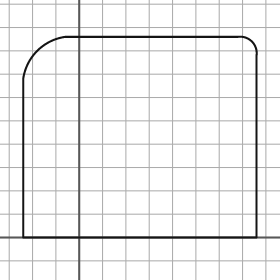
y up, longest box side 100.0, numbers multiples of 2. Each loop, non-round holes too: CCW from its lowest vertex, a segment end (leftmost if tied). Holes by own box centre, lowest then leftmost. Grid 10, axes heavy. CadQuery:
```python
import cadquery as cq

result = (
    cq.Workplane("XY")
    .moveTo(-24.0, 0.0)
    .lineTo(76.0, 0.0)
    .lineTo(76.0, 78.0)
    .threePointArc((74.0, 84.0), (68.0, 86.0))
    .lineTo(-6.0, 86.0)
    .threePointArc((-18.0, 80.0), (-24.0, 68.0))
    .close()
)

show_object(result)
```